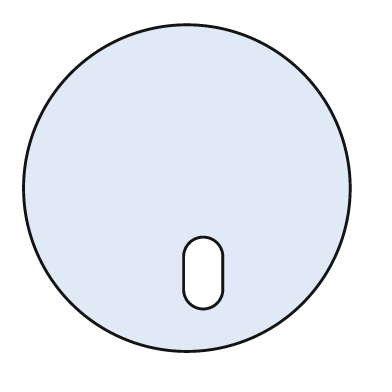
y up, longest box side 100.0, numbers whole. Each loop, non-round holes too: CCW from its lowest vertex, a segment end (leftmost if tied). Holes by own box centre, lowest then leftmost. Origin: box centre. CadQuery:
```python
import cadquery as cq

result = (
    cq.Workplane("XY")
    .moveTo(0.0, 0.0)
    .circle(50.0)
    .moveTo(-1.0, -31.0)
    .threePointArc((5.0, -37.0), (11.0, -31.0))
    .lineTo(11.0, -21.0)
    .threePointArc((5.0, -15.0), (-1.0, -21.0))
    .close()
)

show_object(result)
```